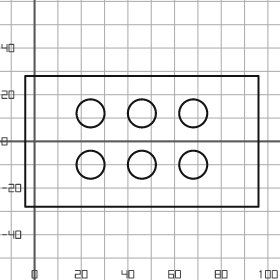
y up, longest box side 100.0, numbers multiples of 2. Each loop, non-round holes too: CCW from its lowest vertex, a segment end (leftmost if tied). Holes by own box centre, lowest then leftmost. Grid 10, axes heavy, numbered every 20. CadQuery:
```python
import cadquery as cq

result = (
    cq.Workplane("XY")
    .moveTo(-4.0, -28.0)
    .lineTo(96.0, -28.0)
    .lineTo(96.0, 28.0)
    .lineTo(-4.0, 28.0)
    .close()
    .moveTo(24.0, -10.0)
    .circle(6.0)
    .moveTo(46.0, -10.0)
    .circle(6.0)
    .moveTo(68.0, -10.0)
    .circle(6.0)
    .moveTo(24.0, 12.0)
    .circle(6.0)
    .moveTo(46.0, 12.0)
    .circle(6.0)
    .moveTo(68.0, 12.0)
    .circle(6.0)
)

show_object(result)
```